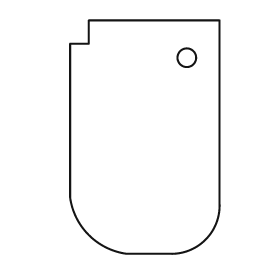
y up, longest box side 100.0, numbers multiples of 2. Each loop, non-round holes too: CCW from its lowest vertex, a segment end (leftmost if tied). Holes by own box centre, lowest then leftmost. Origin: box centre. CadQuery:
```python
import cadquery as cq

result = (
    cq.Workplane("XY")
    .moveTo(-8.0, -50.0)
    .lineTo(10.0, -50.0)
    .threePointArc((26.0, -44.0), (32.0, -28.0))
    .lineTo(32.0, 50.0)
    .lineTo(-24.0, 50.0)
    .lineTo(-24.0, 40.0)
    .lineTo(-32.0, 40.0)
    .lineTo(-32.0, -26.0)
    .threePointArc((-24.0, -42.0), (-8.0, -50.0))
    .close()
    .moveTo(18.0, 34.0)
    .circle(4.0)
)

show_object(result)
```